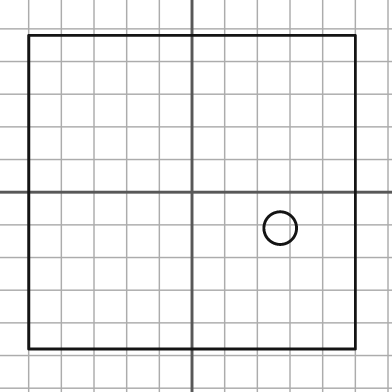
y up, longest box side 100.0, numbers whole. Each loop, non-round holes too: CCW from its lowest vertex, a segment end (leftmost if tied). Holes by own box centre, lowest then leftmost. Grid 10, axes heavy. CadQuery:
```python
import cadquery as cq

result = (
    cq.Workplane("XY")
    .moveTo(-50.0, -48.0)
    .lineTo(50.0, -48.0)
    .lineTo(50.0, 48.0)
    .lineTo(-50.0, 48.0)
    .close()
    .moveTo(27.0, -11.0)
    .circle(5.0)
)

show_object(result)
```